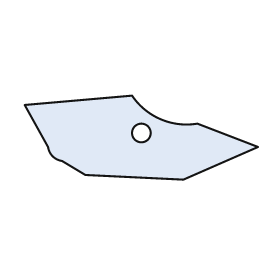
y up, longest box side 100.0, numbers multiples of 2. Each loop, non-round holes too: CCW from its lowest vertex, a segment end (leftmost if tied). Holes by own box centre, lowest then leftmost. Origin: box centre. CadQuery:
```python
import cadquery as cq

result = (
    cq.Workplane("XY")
    .moveTo(18.0, -18.0)
    .lineTo(50.0, -4.0)
    .lineTo(24.0, 6.0)
    .threePointArc((8.0, 8.0), (-4.0, 18.0))
    .lineTo(-50.0, 14.0)
    .lineTo(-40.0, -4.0)
    .threePointArc((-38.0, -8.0), (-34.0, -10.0))
    .lineTo(-24.0, -16.0)
    .close()
    .moveTo(0.0, 2.0)
    .circle(4.0)
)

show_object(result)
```